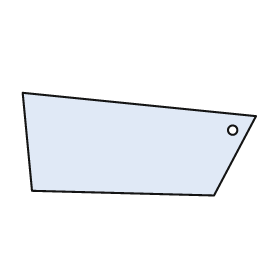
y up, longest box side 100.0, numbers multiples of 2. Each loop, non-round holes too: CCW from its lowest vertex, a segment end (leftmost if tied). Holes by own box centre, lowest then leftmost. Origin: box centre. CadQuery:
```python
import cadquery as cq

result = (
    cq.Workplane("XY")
    .moveTo(32.0, -22.0)
    .lineTo(50.0, 12.0)
    .lineTo(-50.0, 22.0)
    .lineTo(-46.0, -20.0)
    .close()
    .moveTo(40.0, 6.0)
    .circle(2.0)
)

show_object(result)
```